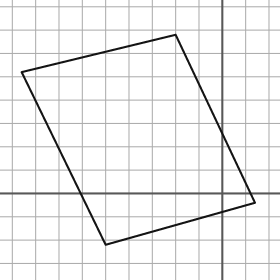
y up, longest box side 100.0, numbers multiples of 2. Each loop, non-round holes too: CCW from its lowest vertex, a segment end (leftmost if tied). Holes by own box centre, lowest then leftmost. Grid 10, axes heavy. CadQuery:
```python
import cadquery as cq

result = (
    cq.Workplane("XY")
    .moveTo(-50.0, -22.0)
    .lineTo(14.0, -4.0)
    .lineTo(-20.0, 68.0)
    .lineTo(-86.0, 52.0)
    .close()
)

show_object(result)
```